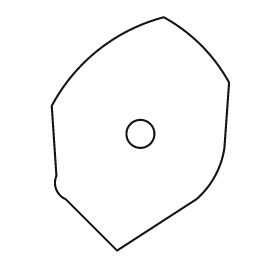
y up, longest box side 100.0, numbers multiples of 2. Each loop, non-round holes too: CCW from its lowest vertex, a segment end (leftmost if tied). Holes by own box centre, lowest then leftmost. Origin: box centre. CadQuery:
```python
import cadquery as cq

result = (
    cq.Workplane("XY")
    .moveTo(-10.0, -50.0)
    .lineTo(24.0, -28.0)
    .threePointArc((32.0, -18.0), (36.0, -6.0))
    .lineTo(38.0, 22.0)
    .threePointArc((26.0, 38.0), (10.0, 50.0))
    .threePointArc((-18.0, 36.0), (-38.0, 12.0))
    .lineTo(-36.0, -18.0)
    .threePointArc((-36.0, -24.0), (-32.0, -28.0))
    .close()
    .moveTo(0.0, 0.0)
    .circle(6.0)
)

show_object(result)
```